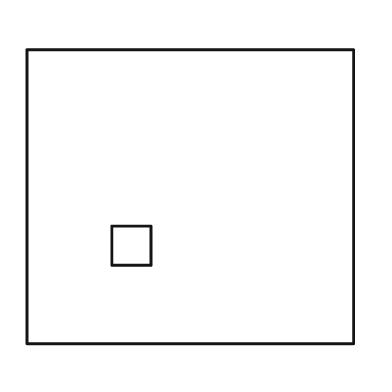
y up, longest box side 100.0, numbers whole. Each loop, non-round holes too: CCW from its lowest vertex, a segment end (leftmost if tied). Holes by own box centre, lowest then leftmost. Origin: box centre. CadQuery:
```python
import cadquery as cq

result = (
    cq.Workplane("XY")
    .moveTo(-50.0, -45.0)
    .lineTo(50.0, -45.0)
    .lineTo(50.0, 45.0)
    .lineTo(-50.0, 45.0)
    .close()
    .moveTo(-24.0, -21.0)
    .lineTo(-12.0, -21.0)
    .lineTo(-12.0, -9.0)
    .lineTo(-24.0, -9.0)
    .close()
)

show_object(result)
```